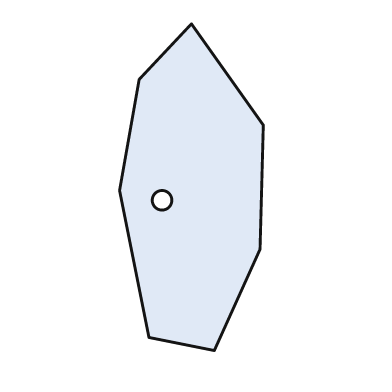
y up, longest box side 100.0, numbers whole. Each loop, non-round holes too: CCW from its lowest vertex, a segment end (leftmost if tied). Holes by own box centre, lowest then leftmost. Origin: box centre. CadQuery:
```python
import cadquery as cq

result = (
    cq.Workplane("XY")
    .moveTo(7.0, -50.0)
    .lineTo(21.0, -19.0)
    .lineTo(22.0, 19.0)
    .lineTo(0.0, 50.0)
    .lineTo(-16.0, 33.0)
    .lineTo(-22.0, -1.0)
    .lineTo(-13.0, -46.0)
    .close()
    .moveTo(-9.0, -4.0)
    .circle(3.0)
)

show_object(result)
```